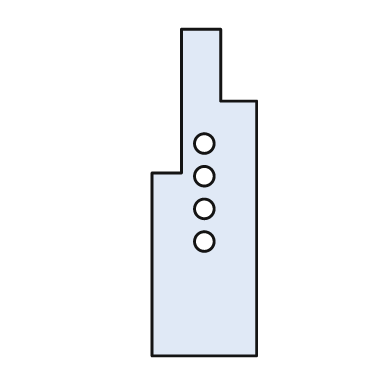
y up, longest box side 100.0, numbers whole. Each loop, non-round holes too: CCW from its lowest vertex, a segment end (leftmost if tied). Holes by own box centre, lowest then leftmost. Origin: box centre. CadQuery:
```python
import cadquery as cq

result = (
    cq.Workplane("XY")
    .moveTo(-16.0, -50.0)
    .lineTo(16.0, -50.0)
    .lineTo(16.0, 28.0)
    .lineTo(5.0, 28.0)
    .lineTo(5.0, 50.0)
    .lineTo(-7.0, 50.0)
    .lineTo(-7.0, 6.0)
    .lineTo(-16.0, 6.0)
    .close()
    .moveTo(0.0, -15.0)
    .circle(3.0)
    .moveTo(0.0, -5.0)
    .circle(3.0)
    .moveTo(0.0, 5.0)
    .circle(3.0)
    .moveTo(0.0, 15.0)
    .circle(3.0)
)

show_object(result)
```